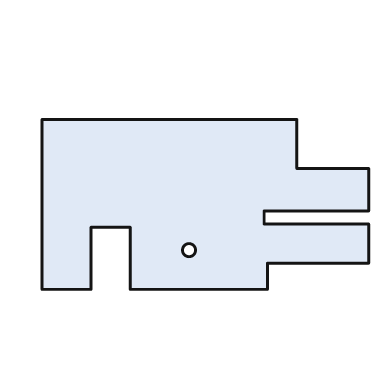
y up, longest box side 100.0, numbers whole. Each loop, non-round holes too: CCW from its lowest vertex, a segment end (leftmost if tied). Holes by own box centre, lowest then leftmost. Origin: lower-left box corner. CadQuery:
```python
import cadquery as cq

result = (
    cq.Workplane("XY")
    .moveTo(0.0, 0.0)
    .lineTo(15.0, 0.0)
    .lineTo(15.0, 19.0)
    .lineTo(27.0, 19.0)
    .lineTo(27.0, 0.0)
    .lineTo(69.0, 0.0)
    .lineTo(69.0, 8.0)
    .lineTo(100.0, 8.0)
    .lineTo(100.0, 20.0)
    .lineTo(68.0, 20.0)
    .lineTo(68.0, 24.0)
    .lineTo(100.0, 24.0)
    .lineTo(100.0, 37.0)
    .lineTo(78.0, 37.0)
    .lineTo(78.0, 52.0)
    .lineTo(0.0, 52.0)
    .close()
    .moveTo(45.0, 12.0)
    .circle(2.0)
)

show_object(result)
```